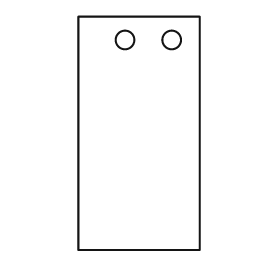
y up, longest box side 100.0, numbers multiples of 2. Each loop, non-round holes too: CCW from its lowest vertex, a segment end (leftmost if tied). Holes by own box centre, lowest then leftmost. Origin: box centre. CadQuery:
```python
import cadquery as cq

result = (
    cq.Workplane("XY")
    .moveTo(-26.0, -50.0)
    .lineTo(26.0, -50.0)
    .lineTo(26.0, 50.0)
    .lineTo(-26.0, 50.0)
    .close()
    .moveTo(-6.0, 40.0)
    .circle(4.0)
    .moveTo(14.0, 40.0)
    .circle(4.0)
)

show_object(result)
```